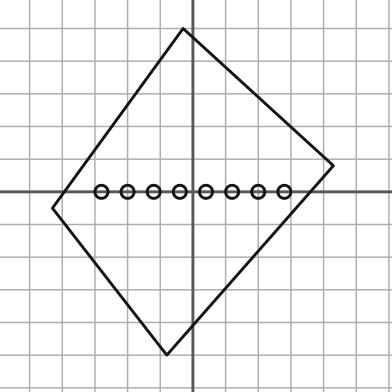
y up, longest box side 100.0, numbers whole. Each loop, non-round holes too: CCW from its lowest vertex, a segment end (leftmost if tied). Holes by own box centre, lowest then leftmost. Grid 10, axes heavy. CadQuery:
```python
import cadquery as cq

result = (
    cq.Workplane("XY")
    .moveTo(-8.0, -50.0)
    .lineTo(43.0, 8.0)
    .lineTo(-3.0, 50.0)
    .lineTo(-43.0, -5.0)
    .close()
    .moveTo(-28.0, 0.0)
    .circle(2.0)
    .moveTo(-20.0, 0.0)
    .circle(2.0)
    .moveTo(-12.0, 0.0)
    .circle(2.0)
    .moveTo(-4.0, 0.0)
    .circle(2.0)
    .moveTo(4.0, 0.0)
    .circle(2.0)
    .moveTo(12.0, 0.0)
    .circle(2.0)
    .moveTo(20.0, 0.0)
    .circle(2.0)
    .moveTo(28.0, 0.0)
    .circle(2.0)
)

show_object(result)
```